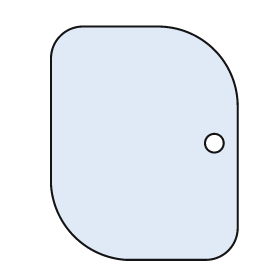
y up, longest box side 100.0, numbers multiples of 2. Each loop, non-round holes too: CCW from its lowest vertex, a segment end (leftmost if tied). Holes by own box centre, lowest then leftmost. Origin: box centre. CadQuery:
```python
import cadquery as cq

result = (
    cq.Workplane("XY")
    .moveTo(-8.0, -50.0)
    .lineTo(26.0, -50.0)
    .threePointArc((36.0, -46.0), (40.0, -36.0))
    .lineTo(40.0, 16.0)
    .threePointArc((30.0, 40.0), (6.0, 50.0))
    .lineTo(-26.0, 50.0)
    .threePointArc((-36.0, 46.0), (-40.0, 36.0))
    .lineTo(-40.0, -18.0)
    .threePointArc((-30.0, -40.0), (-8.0, -50.0))
    .close()
    .moveTo(30.0, 0.0)
    .circle(4.0)
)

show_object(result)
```